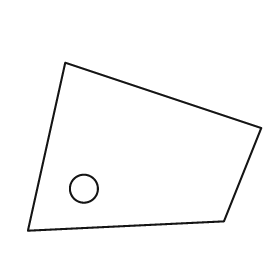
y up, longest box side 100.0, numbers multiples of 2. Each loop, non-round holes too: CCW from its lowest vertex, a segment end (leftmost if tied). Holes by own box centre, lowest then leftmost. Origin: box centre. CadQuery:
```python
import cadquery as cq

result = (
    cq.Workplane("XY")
    .moveTo(-50.0, -36.0)
    .lineTo(34.0, -32.0)
    .lineTo(50.0, 8.0)
    .lineTo(-34.0, 36.0)
    .close()
    .moveTo(-26.0, -18.0)
    .circle(6.0)
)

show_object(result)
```